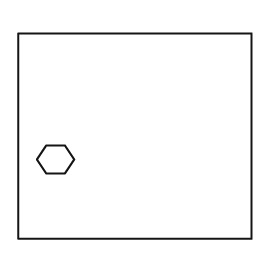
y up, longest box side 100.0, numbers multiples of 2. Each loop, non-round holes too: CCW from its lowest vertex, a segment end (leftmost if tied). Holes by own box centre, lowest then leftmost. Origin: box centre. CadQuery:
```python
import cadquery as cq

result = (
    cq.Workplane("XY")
    .moveTo(-50.0, -44.0)
    .lineTo(50.0, -44.0)
    .lineTo(50.0, 44.0)
    .lineTo(-50.0, 44.0)
    .close()
    .moveTo(-38.0, -16.0)
    .lineTo(-30.0, -16.0)
    .lineTo(-26.0, -10.0)
    .lineTo(-30.0, -4.0)
    .lineTo(-38.0, -4.0)
    .lineTo(-42.0, -10.0)
    .close()
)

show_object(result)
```